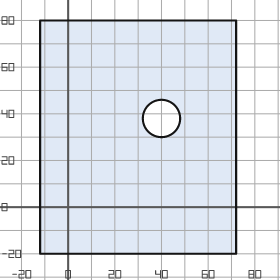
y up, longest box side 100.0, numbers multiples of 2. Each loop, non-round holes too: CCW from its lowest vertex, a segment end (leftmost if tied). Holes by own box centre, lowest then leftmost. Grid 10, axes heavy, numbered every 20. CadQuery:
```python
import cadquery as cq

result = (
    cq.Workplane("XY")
    .moveTo(-12.0, -20.0)
    .lineTo(72.0, -20.0)
    .lineTo(72.0, 80.0)
    .lineTo(-12.0, 80.0)
    .close()
    .moveTo(40.0, 38.0)
    .circle(8.0)
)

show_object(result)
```